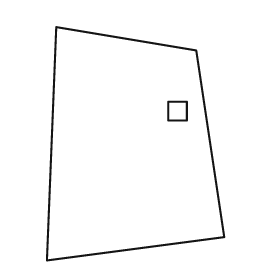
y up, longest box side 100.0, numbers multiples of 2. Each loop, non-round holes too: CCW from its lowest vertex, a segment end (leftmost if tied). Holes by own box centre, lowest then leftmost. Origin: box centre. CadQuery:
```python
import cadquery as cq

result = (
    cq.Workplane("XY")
    .moveTo(-38.0, -50.0)
    .lineTo(38.0, -40.0)
    .lineTo(26.0, 40.0)
    .lineTo(-34.0, 50.0)
    .close()
    .moveTo(14.0, 10.0)
    .lineTo(22.0, 10.0)
    .lineTo(22.0, 18.0)
    .lineTo(14.0, 18.0)
    .close()
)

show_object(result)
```